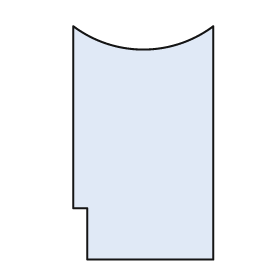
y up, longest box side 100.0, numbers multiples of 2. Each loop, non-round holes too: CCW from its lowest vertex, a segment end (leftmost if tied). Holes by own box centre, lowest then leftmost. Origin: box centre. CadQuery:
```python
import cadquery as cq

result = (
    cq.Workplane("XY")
    .moveTo(-24.0, -50.0)
    .lineTo(30.0, -50.0)
    .lineTo(30.0, 50.0)
    .threePointArc((0.0, 40.0), (-30.0, 50.0))
    .lineTo(-30.0, -28.0)
    .lineTo(-24.0, -28.0)
    .close()
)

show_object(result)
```